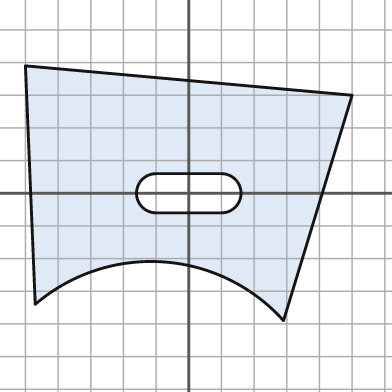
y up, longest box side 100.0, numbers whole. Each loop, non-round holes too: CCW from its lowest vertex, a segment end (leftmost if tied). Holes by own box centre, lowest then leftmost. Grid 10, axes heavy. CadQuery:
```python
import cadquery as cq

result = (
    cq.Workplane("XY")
    .moveTo(29.0, -39.0)
    .lineTo(50.0, 30.0)
    .lineTo(-50.0, 39.0)
    .lineTo(-47.0, -34.0)
    .threePointArc((-8.0, -21.0), (29.0, -39.0))
    .close()
    .moveTo(-10.0, -6.0)
    .lineTo(10.0, -6.0)
    .threePointArc((16.0, 0.0), (10.0, 6.0))
    .lineTo(-10.0, 6.0)
    .threePointArc((-16.0, 0.0), (-10.0, -6.0))
    .close()
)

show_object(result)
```